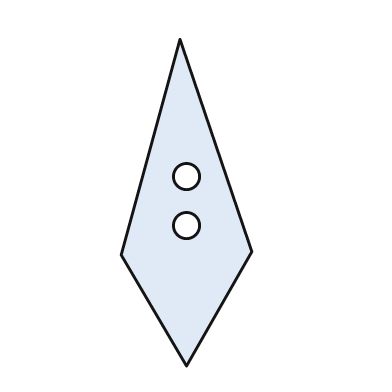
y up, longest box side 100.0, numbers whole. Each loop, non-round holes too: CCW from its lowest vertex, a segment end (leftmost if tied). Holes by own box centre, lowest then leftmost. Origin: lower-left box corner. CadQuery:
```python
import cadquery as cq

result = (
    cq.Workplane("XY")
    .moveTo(20.0, 0.0)
    .lineTo(40.0, 35.0)
    .lineTo(18.0, 100.0)
    .lineTo(0.0, 34.0)
    .close()
    .moveTo(20.0, 43.0)
    .circle(4.0)
    .moveTo(20.0, 58.0)
    .circle(4.0)
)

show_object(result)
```